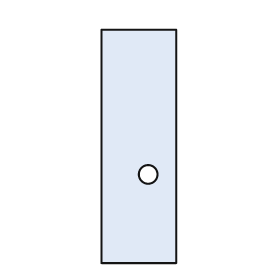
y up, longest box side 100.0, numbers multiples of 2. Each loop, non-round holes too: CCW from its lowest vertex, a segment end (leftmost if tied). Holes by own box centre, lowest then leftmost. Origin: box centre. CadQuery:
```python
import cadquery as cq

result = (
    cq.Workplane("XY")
    .moveTo(-16.0, -50.0)
    .lineTo(16.0, -50.0)
    .lineTo(16.0, 50.0)
    .lineTo(-16.0, 50.0)
    .close()
    .moveTo(4.0, -12.0)
    .circle(4.0)
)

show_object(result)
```